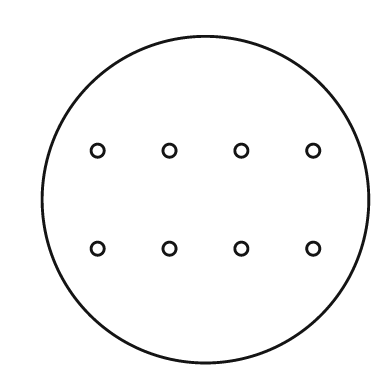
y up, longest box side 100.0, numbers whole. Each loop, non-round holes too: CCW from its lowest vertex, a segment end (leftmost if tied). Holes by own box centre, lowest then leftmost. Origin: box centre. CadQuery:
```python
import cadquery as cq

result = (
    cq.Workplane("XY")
    .moveTo(0.0, 0.0)
    .circle(50.0)
    .moveTo(-33.0, -15.0)
    .circle(2.0)
    .moveTo(-11.0, -15.0)
    .circle(2.0)
    .moveTo(11.0, -15.0)
    .circle(2.0)
    .moveTo(33.0, -15.0)
    .circle(2.0)
    .moveTo(-33.0, 15.0)
    .circle(2.0)
    .moveTo(-11.0, 15.0)
    .circle(2.0)
    .moveTo(11.0, 15.0)
    .circle(2.0)
    .moveTo(33.0, 15.0)
    .circle(2.0)
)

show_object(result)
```